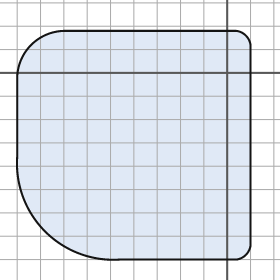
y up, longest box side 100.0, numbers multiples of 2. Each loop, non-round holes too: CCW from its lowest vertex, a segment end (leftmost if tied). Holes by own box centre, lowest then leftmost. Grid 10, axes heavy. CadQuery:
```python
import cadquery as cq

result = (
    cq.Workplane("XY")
    .moveTo(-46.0, -80.0)
    .lineTo(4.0, -80.0)
    .threePointArc((8.0, -78.0), (10.0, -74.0))
    .lineTo(10.0, 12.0)
    .threePointArc((8.0, 16.0), (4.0, 18.0))
    .lineTo(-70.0, 18.0)
    .threePointArc((-84.0, 12.0), (-90.0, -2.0))
    .lineTo(-90.0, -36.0)
    .threePointArc((-78.0, -68.0), (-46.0, -80.0))
    .close()
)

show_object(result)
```